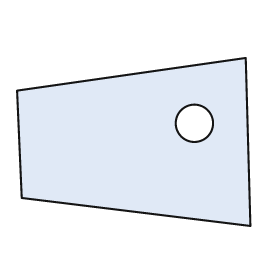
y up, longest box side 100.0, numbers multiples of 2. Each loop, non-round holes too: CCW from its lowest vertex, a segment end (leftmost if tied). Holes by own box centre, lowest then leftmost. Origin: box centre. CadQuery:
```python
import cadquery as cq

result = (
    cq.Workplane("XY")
    .moveTo(50.0, -36.0)
    .lineTo(48.0, 36.0)
    .lineTo(-50.0, 22.0)
    .lineTo(-48.0, -24.0)
    .close()
    .moveTo(26.0, 8.0)
    .circle(8.0)
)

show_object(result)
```